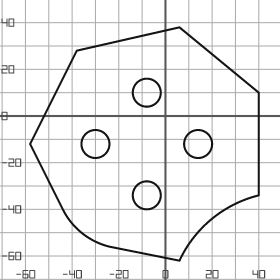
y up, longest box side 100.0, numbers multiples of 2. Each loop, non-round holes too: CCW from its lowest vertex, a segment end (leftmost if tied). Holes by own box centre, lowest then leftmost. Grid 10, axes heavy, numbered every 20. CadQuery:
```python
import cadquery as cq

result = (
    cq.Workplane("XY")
    .moveTo(6.0, -62.0)
    .threePointArc((20.0, -44.0), (40.0, -34.0))
    .lineTo(40.0, 10.0)
    .lineTo(6.0, 38.0)
    .lineTo(-38.0, 28.0)
    .lineTo(-58.0, -12.0)
    .lineTo(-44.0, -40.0)
    .threePointArc((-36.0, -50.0), (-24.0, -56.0))
    .close()
    .moveTo(-8.0, -34.0)
    .circle(6.0)
    .moveTo(-30.0, -12.0)
    .circle(6.0)
    .moveTo(14.0, -12.0)
    .circle(6.0)
    .moveTo(-8.0, 10.0)
    .circle(6.0)
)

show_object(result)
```